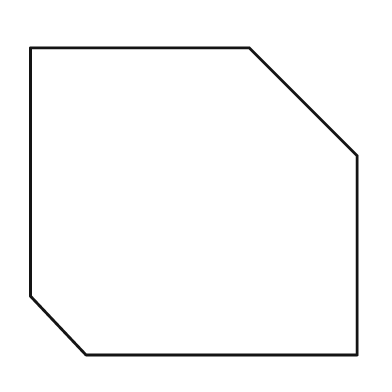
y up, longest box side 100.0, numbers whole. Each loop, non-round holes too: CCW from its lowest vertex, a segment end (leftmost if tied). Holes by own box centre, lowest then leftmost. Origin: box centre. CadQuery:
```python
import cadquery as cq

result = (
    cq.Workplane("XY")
    .moveTo(-33.0, -47.0)
    .lineTo(50.0, -47.0)
    .lineTo(50.0, 14.0)
    .lineTo(17.0, 47.0)
    .lineTo(-50.0, 47.0)
    .lineTo(-50.0, -29.0)
    .close()
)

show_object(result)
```